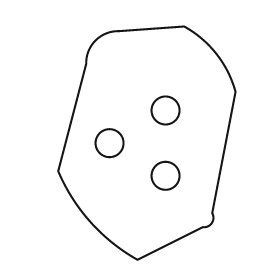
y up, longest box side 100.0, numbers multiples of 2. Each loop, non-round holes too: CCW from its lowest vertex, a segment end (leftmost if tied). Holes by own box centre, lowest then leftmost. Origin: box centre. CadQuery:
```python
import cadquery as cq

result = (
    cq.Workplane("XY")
    .moveTo(-4.0, -50.0)
    .lineTo(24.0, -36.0)
    .threePointArc((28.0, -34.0), (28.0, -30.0))
    .lineTo(38.0, 22.0)
    .threePointArc((30.0, 38.0), (16.0, 50.0))
    .lineTo(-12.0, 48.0)
    .threePointArc((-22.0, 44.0), (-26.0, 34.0))
    .lineTo(-38.0, -12.0)
    .threePointArc((-24.0, -34.0), (-4.0, -50.0))
    .close()
    .moveTo(8.0, -14.0)
    .circle(6.0)
    .moveTo(-16.0, 0.0)
    .circle(6.0)
    .moveTo(8.0, 14.0)
    .circle(6.0)
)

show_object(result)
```